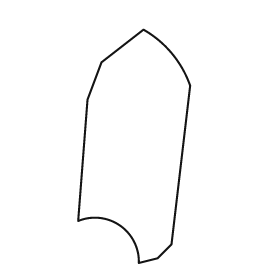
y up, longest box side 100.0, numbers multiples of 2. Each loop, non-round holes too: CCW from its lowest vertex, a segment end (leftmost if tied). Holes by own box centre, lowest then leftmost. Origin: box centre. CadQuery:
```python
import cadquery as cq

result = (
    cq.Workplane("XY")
    .moveTo(2.0, -50.0)
    .lineTo(10.0, -48.0)
    .lineTo(16.0, -42.0)
    .lineTo(24.0, 26.0)
    .threePointArc((16.0, 40.0), (4.0, 50.0))
    .lineTo(-14.0, 36.0)
    .lineTo(-20.0, 20.0)
    .lineTo(-24.0, -32.0)
    .threePointArc((-6.0, -34.0), (2.0, -50.0))
    .close()
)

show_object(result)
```